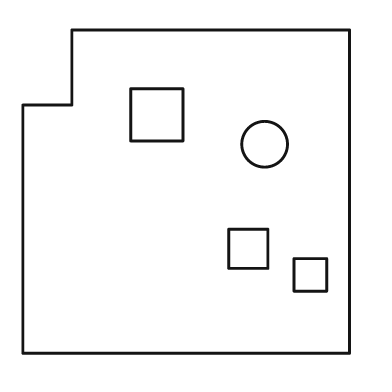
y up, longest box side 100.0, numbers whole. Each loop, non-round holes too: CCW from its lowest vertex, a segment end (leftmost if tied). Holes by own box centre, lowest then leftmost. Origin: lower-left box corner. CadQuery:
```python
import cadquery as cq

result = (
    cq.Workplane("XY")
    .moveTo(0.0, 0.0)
    .lineTo(100.0, 0.0)
    .lineTo(100.0, 99.0)
    .lineTo(15.0, 99.0)
    .lineTo(15.0, 76.0)
    .lineTo(0.0, 76.0)
    .close()
    .moveTo(83.0, 19.0)
    .lineTo(93.0, 19.0)
    .lineTo(93.0, 29.0)
    .lineTo(83.0, 29.0)
    .close()
    .moveTo(63.0, 26.0)
    .lineTo(75.0, 26.0)
    .lineTo(75.0, 38.0)
    .lineTo(63.0, 38.0)
    .close()
    .moveTo(74.0, 64.0)
    .circle(7.0)
    .moveTo(33.0, 65.0)
    .lineTo(49.0, 65.0)
    .lineTo(49.0, 81.0)
    .lineTo(33.0, 81.0)
    .close()
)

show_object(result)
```